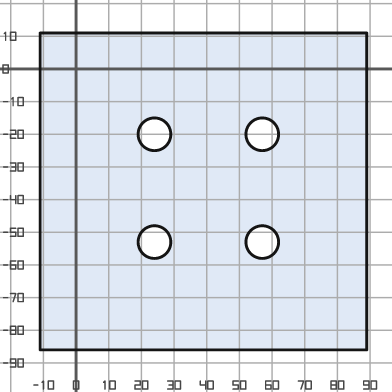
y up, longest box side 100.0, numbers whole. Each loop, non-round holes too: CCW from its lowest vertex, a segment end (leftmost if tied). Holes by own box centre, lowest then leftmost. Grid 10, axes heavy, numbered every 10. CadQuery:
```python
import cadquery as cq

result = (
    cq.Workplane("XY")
    .moveTo(-11.0, -86.0)
    .lineTo(89.0, -86.0)
    .lineTo(89.0, 11.0)
    .lineTo(-11.0, 11.0)
    .close()
    .moveTo(24.0, -53.0)
    .circle(5.0)
    .moveTo(57.0, -53.0)
    .circle(5.0)
    .moveTo(24.0, -20.0)
    .circle(5.0)
    .moveTo(57.0, -20.0)
    .circle(5.0)
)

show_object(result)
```